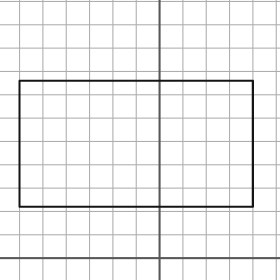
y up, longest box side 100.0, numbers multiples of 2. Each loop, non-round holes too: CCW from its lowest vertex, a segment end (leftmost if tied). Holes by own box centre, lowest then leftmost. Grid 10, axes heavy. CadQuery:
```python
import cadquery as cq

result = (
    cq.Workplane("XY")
    .moveTo(-60.0, 22.0)
    .lineTo(40.0, 22.0)
    .lineTo(40.0, 76.0)
    .lineTo(-60.0, 76.0)
    .close()
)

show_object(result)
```